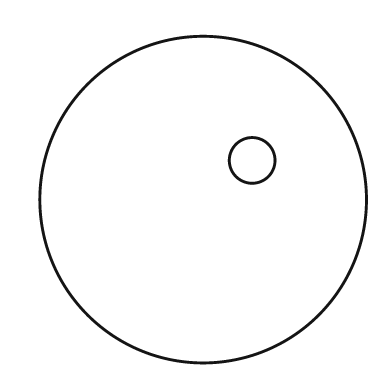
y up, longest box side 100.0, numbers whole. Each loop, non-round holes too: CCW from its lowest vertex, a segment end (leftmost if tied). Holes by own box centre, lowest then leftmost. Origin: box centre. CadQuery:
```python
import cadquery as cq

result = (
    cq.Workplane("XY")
    .moveTo(0.0, 0.0)
    .circle(50.0)
    .moveTo(15.0, 12.0)
    .circle(7.0)
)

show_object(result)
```